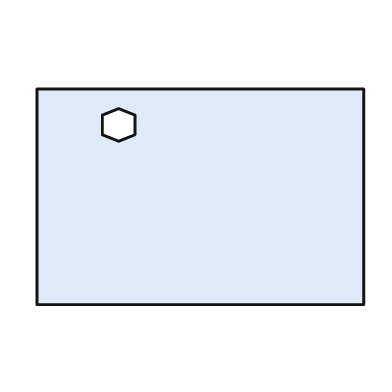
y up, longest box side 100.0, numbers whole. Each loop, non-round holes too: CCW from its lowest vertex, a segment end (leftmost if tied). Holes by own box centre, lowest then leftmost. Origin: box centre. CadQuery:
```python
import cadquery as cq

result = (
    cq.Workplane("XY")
    .moveTo(-50.0, -33.0)
    .lineTo(50.0, -33.0)
    .lineTo(50.0, 33.0)
    .lineTo(-50.0, 33.0)
    .close()
    .moveTo(-25.0, 17.0)
    .lineTo(-20.0, 19.0)
    .lineTo(-20.0, 25.0)
    .lineTo(-25.0, 27.0)
    .lineTo(-30.0, 25.0)
    .lineTo(-30.0, 19.0)
    .close()
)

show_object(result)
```